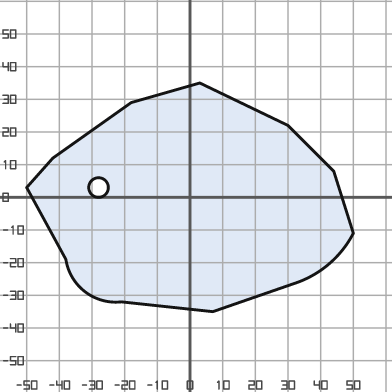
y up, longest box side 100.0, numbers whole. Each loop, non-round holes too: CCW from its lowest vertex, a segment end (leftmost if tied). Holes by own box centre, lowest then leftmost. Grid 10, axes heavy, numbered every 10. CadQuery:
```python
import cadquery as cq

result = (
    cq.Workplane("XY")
    .moveTo(7.0, -35.0)
    .lineTo(33.0, -26.0)
    .threePointArc((43.0, -20.0), (50.0, -11.0))
    .lineTo(44.0, 8.0)
    .lineTo(30.0, 22.0)
    .lineTo(3.0, 35.0)
    .lineTo(-18.0, 29.0)
    .lineTo(-42.0, 12.0)
    .lineTo(-50.0, 3.0)
    .lineTo(-38.0, -19.0)
    .threePointArc((-32.0, -29.0), (-21.0, -32.0))
    .close()
    .moveTo(-28.0, 3.0)
    .circle(3.0)
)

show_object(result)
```